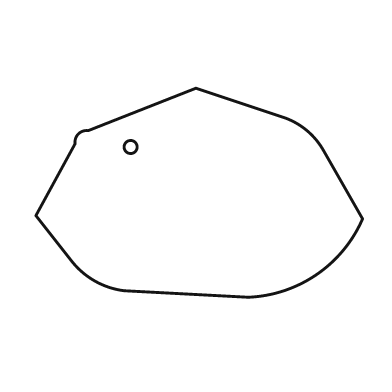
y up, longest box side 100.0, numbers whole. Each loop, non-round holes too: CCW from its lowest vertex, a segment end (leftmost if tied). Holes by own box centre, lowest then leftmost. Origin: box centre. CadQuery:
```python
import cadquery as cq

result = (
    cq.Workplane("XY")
    .moveTo(15.0, -32.0)
    .threePointArc((36.0, -25.0), (50.0, -8.0))
    .lineTo(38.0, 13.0)
    .threePointArc((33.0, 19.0), (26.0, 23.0))
    .lineTo(-1.0, 32.0)
    .lineTo(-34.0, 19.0)
    .threePointArc((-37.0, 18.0), (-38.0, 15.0))
    .lineTo(-50.0, -7.0)
    .lineTo(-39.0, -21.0)
    .threePointArc((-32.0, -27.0), (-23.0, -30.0))
    .close()
    .moveTo(-21.0, 14.0)
    .circle(2.0)
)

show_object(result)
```